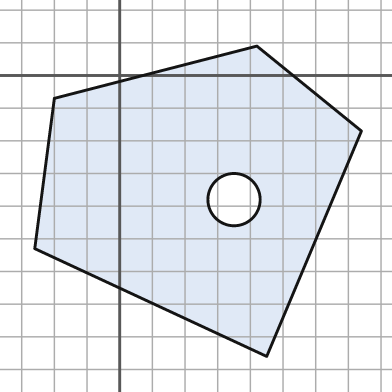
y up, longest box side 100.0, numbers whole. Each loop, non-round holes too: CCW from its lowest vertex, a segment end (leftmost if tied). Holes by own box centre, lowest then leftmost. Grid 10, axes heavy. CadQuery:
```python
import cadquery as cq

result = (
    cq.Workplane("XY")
    .moveTo(45.0, -86.0)
    .lineTo(74.0, -17.0)
    .lineTo(42.0, 9.0)
    .lineTo(-20.0, -7.0)
    .lineTo(-26.0, -53.0)
    .close()
    .moveTo(35.0, -38.0)
    .circle(8.0)
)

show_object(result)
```